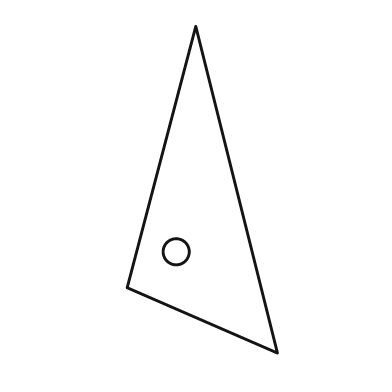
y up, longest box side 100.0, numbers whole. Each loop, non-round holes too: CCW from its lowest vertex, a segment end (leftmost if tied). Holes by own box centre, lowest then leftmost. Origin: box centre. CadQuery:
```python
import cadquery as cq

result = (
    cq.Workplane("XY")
    .moveTo(23.0, -50.0)
    .lineTo(-2.0, 50.0)
    .lineTo(-23.0, -30.0)
    .close()
    .moveTo(-8.0, -19.0)
    .circle(4.0)
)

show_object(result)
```